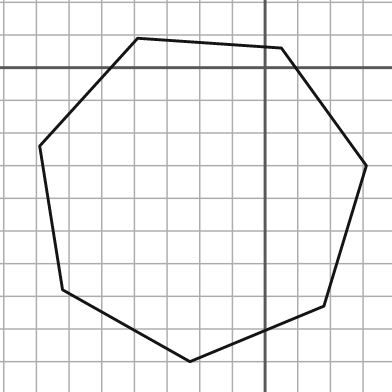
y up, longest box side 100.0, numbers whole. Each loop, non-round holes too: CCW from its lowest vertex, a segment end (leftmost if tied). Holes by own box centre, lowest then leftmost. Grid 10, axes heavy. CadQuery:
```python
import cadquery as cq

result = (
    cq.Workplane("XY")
    .moveTo(-23.0, -90.0)
    .lineTo(18.0, -73.0)
    .lineTo(31.0, -30.0)
    .lineTo(5.0, 6.0)
    .lineTo(-39.0, 9.0)
    .lineTo(-69.0, -24.0)
    .lineTo(-62.0, -68.0)
    .close()
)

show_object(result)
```